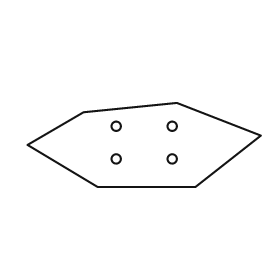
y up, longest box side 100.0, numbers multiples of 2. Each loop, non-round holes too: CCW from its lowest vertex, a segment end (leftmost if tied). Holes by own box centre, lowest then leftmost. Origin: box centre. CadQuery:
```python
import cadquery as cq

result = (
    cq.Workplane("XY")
    .moveTo(-20.0, -18.0)
    .lineTo(22.0, -18.0)
    .lineTo(50.0, 4.0)
    .lineTo(14.0, 18.0)
    .lineTo(-26.0, 14.0)
    .lineTo(-50.0, 0.0)
    .close()
    .moveTo(-12.0, -6.0)
    .circle(2.0)
    .moveTo(12.0, -6.0)
    .circle(2.0)
    .moveTo(-12.0, 8.0)
    .circle(2.0)
    .moveTo(12.0, 8.0)
    .circle(2.0)
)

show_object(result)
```